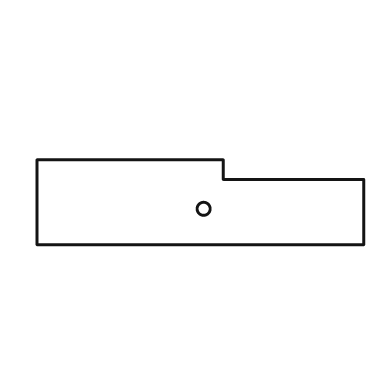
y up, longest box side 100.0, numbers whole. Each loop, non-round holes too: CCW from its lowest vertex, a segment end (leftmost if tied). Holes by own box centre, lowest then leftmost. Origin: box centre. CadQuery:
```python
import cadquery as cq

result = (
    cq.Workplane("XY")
    .moveTo(-50.0, -13.0)
    .lineTo(50.0, -13.0)
    .lineTo(50.0, 7.0)
    .lineTo(7.0, 7.0)
    .lineTo(7.0, 13.0)
    .lineTo(-50.0, 13.0)
    .close()
    .moveTo(1.0, -2.0)
    .circle(2.0)
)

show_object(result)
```